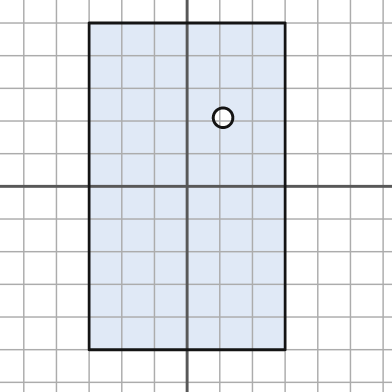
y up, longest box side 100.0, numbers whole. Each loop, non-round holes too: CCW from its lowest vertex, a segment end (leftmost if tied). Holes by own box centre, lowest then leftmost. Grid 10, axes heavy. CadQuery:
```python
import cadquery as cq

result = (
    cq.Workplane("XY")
    .moveTo(-30.0, -50.0)
    .lineTo(30.0, -50.0)
    .lineTo(30.0, 50.0)
    .lineTo(-30.0, 50.0)
    .close()
    .moveTo(11.0, 21.0)
    .circle(3.0)
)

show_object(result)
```